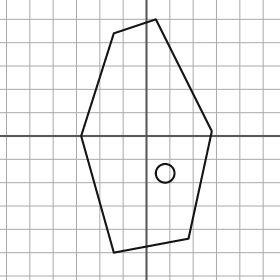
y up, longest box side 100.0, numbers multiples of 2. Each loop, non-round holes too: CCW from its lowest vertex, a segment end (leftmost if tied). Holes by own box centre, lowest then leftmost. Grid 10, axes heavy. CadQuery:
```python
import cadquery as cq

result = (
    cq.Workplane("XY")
    .moveTo(-14.0, -50.0)
    .lineTo(18.0, -44.0)
    .lineTo(28.0, 2.0)
    .lineTo(4.0, 50.0)
    .lineTo(-14.0, 44.0)
    .lineTo(-28.0, 0.0)
    .close()
    .moveTo(8.0, -16.0)
    .circle(4.0)
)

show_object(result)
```